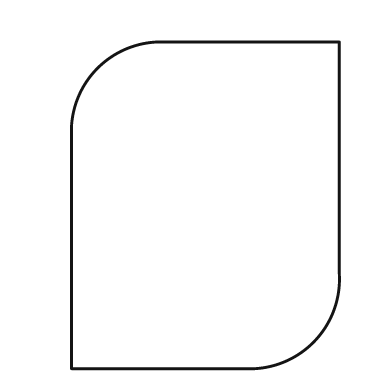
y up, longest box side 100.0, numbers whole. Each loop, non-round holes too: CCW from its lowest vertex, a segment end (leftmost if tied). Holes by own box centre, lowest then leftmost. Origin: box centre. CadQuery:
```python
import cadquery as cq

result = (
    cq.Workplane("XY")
    .moveTo(-41.0, -50.0)
    .lineTo(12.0, -50.0)
    .threePointArc((33.0, -42.0), (41.0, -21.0))
    .lineTo(41.0, 50.0)
    .lineTo(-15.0, 50.0)
    .threePointArc((-33.0, 42.0), (-41.0, 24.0))
    .close()
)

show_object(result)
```